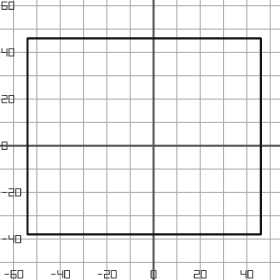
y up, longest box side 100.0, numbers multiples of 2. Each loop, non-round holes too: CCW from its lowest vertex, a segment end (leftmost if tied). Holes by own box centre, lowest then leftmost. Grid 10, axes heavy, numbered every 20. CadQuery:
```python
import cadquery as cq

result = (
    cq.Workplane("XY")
    .moveTo(-54.0, -38.0)
    .lineTo(46.0, -38.0)
    .lineTo(46.0, 46.0)
    .lineTo(-54.0, 46.0)
    .close()
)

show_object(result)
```